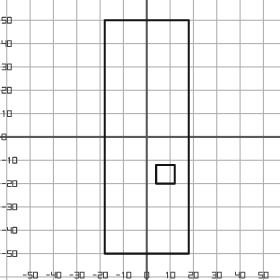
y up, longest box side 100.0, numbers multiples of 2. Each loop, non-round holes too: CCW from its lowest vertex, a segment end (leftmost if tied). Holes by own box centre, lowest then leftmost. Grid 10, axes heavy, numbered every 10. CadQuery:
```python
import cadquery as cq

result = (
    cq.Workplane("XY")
    .moveTo(-18.0, -50.0)
    .lineTo(18.0, -50.0)
    .lineTo(18.0, 50.0)
    .lineTo(-18.0, 50.0)
    .close()
    .moveTo(4.0, -20.0)
    .lineTo(12.0, -20.0)
    .lineTo(12.0, -12.0)
    .lineTo(4.0, -12.0)
    .close()
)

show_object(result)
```